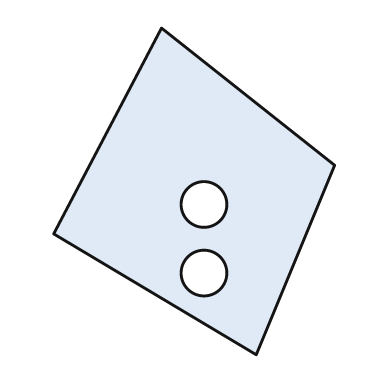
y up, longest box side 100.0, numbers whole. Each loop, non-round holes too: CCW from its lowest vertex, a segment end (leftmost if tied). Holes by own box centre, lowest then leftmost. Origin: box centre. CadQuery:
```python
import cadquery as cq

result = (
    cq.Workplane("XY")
    .moveTo(19.0, -50.0)
    .lineTo(43.0, 8.0)
    .lineTo(-10.0, 50.0)
    .lineTo(-43.0, -13.0)
    .close()
    .moveTo(3.0, -25.0)
    .circle(7.0)
    .moveTo(3.0, -4.0)
    .circle(7.0)
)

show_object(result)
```